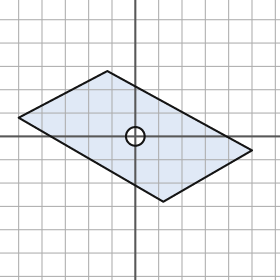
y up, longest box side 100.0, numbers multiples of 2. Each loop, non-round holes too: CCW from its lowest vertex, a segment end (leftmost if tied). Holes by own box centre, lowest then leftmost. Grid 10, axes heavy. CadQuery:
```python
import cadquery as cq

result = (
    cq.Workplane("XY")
    .moveTo(12.0, -28.0)
    .lineTo(50.0, -6.0)
    .lineTo(-12.0, 28.0)
    .lineTo(-50.0, 8.0)
    .close()
    .moveTo(0.0, 0.0)
    .circle(4.0)
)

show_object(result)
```